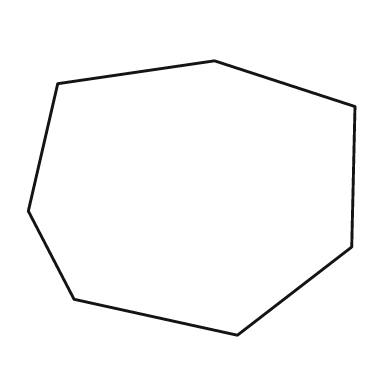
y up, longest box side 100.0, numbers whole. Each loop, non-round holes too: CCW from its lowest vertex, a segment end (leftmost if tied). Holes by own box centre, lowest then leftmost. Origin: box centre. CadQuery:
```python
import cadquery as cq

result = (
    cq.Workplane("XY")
    .moveTo(14.0, -42.0)
    .lineTo(49.0, -15.0)
    .lineTo(50.0, 28.0)
    .lineTo(7.0, 42.0)
    .lineTo(-41.0, 35.0)
    .lineTo(-50.0, -4.0)
    .lineTo(-36.0, -31.0)
    .close()
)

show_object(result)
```